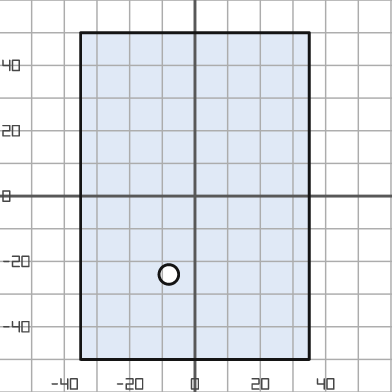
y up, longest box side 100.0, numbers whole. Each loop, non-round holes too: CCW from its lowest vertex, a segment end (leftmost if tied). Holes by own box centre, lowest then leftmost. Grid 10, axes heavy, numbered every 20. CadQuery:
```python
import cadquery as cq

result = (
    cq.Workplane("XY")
    .moveTo(-35.0, -50.0)
    .lineTo(35.0, -50.0)
    .lineTo(35.0, 50.0)
    .lineTo(-35.0, 50.0)
    .close()
    .moveTo(-8.0, -24.0)
    .circle(3.0)
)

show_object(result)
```